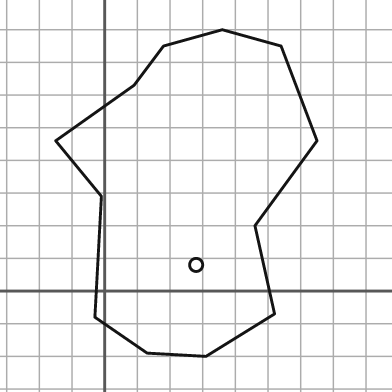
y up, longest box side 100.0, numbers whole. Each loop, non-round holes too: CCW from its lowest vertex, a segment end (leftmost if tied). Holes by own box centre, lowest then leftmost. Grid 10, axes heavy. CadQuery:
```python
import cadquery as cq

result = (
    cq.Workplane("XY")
    .moveTo(31.0, -20.0)
    .lineTo(52.0, -7.0)
    .lineTo(46.0, 20.0)
    .lineTo(65.0, 46.0)
    .lineTo(54.0, 75.0)
    .lineTo(36.0, 80.0)
    .lineTo(18.0, 75.0)
    .lineTo(9.0, 63.0)
    .lineTo(-15.0, 46.0)
    .lineTo(-1.0, 29.0)
    .lineTo(-3.0, -8.0)
    .lineTo(13.0, -19.0)
    .close()
    .moveTo(28.0, 8.0)
    .circle(2.0)
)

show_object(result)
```